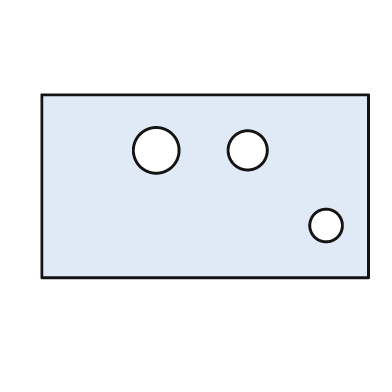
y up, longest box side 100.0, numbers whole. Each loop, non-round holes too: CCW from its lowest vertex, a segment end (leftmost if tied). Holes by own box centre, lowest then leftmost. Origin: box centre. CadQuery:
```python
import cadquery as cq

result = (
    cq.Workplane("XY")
    .moveTo(-50.0, -28.0)
    .lineTo(50.0, -28.0)
    .lineTo(50.0, 28.0)
    .lineTo(-50.0, 28.0)
    .close()
    .moveTo(37.0, -12.0)
    .circle(5.0)
    .moveTo(-15.0, 11.0)
    .circle(7.0)
    .moveTo(13.0, 11.0)
    .circle(6.0)
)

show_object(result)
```